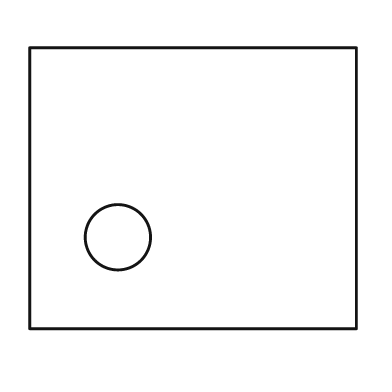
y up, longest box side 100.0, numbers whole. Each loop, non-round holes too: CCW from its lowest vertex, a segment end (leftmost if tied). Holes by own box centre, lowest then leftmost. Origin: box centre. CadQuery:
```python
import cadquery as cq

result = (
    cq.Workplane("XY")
    .moveTo(-50.0, -43.0)
    .lineTo(50.0, -43.0)
    .lineTo(50.0, 43.0)
    .lineTo(-50.0, 43.0)
    .close()
    .moveTo(-23.0, -15.0)
    .circle(10.0)
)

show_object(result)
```